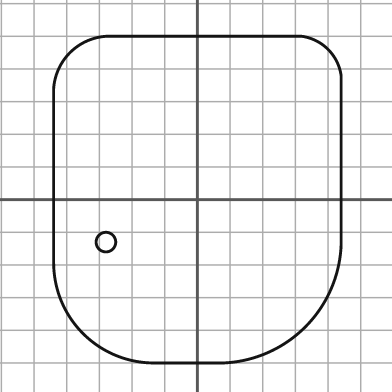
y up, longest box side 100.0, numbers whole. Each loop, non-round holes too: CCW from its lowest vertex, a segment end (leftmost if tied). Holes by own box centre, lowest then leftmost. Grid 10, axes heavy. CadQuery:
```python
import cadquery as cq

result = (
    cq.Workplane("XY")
    .moveTo(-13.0, -50.0)
    .lineTo(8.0, -50.0)
    .threePointArc((33.0, -39.0), (44.0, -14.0))
    .lineTo(44.0, 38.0)
    .threePointArc((40.0, 46.0), (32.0, 50.0))
    .lineTo(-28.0, 50.0)
    .threePointArc((-39.0, 45.0), (-44.0, 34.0))
    .lineTo(-44.0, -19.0)
    .threePointArc((-35.0, -41.0), (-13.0, -50.0))
    .close()
    .moveTo(-28.0, -13.0)
    .circle(3.0)
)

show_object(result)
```